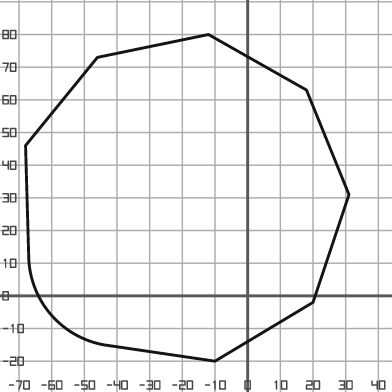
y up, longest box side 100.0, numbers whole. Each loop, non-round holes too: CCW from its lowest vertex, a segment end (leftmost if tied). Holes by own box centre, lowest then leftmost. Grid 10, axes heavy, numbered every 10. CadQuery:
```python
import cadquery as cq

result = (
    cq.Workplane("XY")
    .moveTo(-10.0, -20.0)
    .lineTo(20.0, -2.0)
    .lineTo(31.0, 31.0)
    .lineTo(18.0, 63.0)
    .lineTo(-12.0, 80.0)
    .lineTo(-46.0, 73.0)
    .lineTo(-68.0, 46.0)
    .lineTo(-67.0, 11.0)
    .threePointArc((-60.0, -6.0), (-44.0, -15.0))
    .close()
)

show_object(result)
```